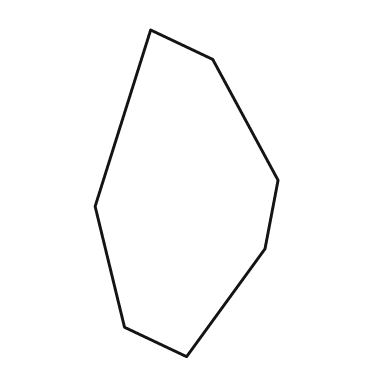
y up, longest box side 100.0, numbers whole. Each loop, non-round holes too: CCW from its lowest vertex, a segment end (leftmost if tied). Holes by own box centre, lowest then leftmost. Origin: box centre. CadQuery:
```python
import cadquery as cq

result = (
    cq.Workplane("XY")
    .moveTo(0.0, -50.0)
    .lineTo(24.0, -17.0)
    .lineTo(28.0, 4.0)
    .lineTo(8.0, 41.0)
    .lineTo(-11.0, 50.0)
    .lineTo(-28.0, -4.0)
    .lineTo(-19.0, -41.0)
    .close()
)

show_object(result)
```